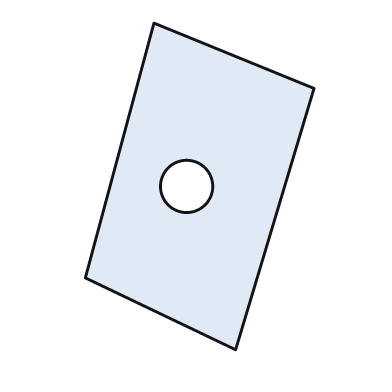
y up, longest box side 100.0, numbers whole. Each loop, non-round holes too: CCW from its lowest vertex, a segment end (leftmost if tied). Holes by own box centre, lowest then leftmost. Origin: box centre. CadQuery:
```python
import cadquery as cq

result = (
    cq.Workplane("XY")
    .moveTo(11.0, -50.0)
    .lineTo(35.0, 30.0)
    .lineTo(-14.0, 50.0)
    .lineTo(-35.0, -28.0)
    .close()
    .moveTo(-4.0, 0.0)
    .circle(8.0)
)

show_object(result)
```